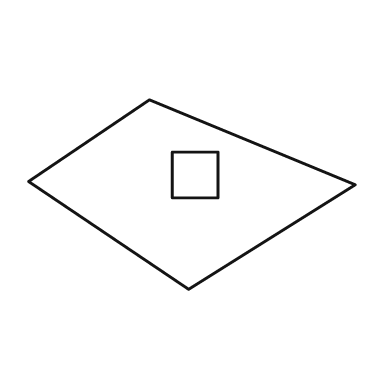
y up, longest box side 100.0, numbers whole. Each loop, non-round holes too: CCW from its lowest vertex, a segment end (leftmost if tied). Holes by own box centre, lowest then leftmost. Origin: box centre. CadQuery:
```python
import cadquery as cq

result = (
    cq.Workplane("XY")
    .moveTo(-1.0, -29.0)
    .lineTo(50.0, 3.0)
    .lineTo(-13.0, 29.0)
    .lineTo(-50.0, 4.0)
    .close()
    .moveTo(-6.0, -1.0)
    .lineTo(8.0, -1.0)
    .lineTo(8.0, 13.0)
    .lineTo(-6.0, 13.0)
    .close()
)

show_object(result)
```